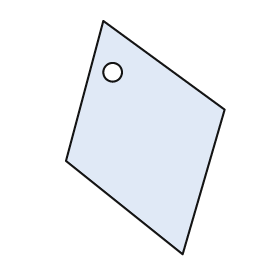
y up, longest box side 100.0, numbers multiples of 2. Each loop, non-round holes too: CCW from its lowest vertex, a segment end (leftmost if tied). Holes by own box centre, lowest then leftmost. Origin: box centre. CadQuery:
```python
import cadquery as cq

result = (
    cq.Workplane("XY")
    .moveTo(16.0, -50.0)
    .lineTo(34.0, 12.0)
    .lineTo(-18.0, 50.0)
    .lineTo(-34.0, -10.0)
    .close()
    .moveTo(-14.0, 28.0)
    .circle(4.0)
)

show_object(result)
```